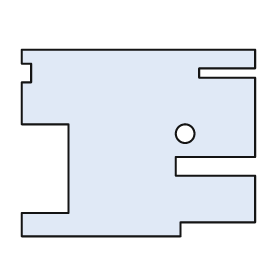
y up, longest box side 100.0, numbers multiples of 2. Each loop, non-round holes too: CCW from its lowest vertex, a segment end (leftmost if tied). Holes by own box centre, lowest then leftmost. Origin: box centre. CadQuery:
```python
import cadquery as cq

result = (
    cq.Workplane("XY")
    .moveTo(-50.0, -40.0)
    .lineTo(18.0, -40.0)
    .lineTo(18.0, -34.0)
    .lineTo(50.0, -34.0)
    .lineTo(50.0, -14.0)
    .lineTo(16.0, -14.0)
    .lineTo(16.0, -6.0)
    .lineTo(50.0, -6.0)
    .lineTo(50.0, 28.0)
    .lineTo(26.0, 28.0)
    .lineTo(26.0, 32.0)
    .lineTo(50.0, 32.0)
    .lineTo(50.0, 40.0)
    .lineTo(-50.0, 40.0)
    .lineTo(-50.0, 34.0)
    .lineTo(-46.0, 34.0)
    .lineTo(-46.0, 26.0)
    .lineTo(-50.0, 26.0)
    .lineTo(-50.0, 8.0)
    .lineTo(-30.0, 8.0)
    .lineTo(-30.0, -30.0)
    .lineTo(-50.0, -30.0)
    .close()
    .moveTo(20.0, 4.0)
    .circle(4.0)
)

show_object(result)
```